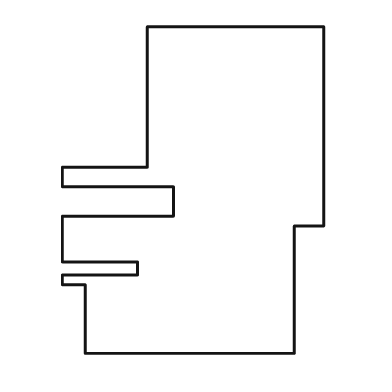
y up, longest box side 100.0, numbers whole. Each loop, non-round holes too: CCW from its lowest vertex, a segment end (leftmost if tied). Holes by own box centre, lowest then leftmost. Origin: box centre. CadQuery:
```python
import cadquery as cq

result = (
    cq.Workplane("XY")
    .moveTo(-33.0, -50.0)
    .lineTo(31.0, -50.0)
    .lineTo(31.0, -11.0)
    .lineTo(40.0, -11.0)
    .lineTo(40.0, 50.0)
    .lineTo(-14.0, 50.0)
    .lineTo(-14.0, 7.0)
    .lineTo(-40.0, 7.0)
    .lineTo(-40.0, 1.0)
    .lineTo(-6.0, 1.0)
    .lineTo(-6.0, -8.0)
    .lineTo(-40.0, -8.0)
    .lineTo(-40.0, -22.0)
    .lineTo(-17.0, -22.0)
    .lineTo(-17.0, -26.0)
    .lineTo(-40.0, -26.0)
    .lineTo(-40.0, -29.0)
    .lineTo(-33.0, -29.0)
    .close()
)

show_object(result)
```